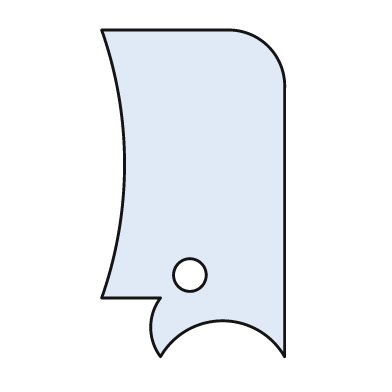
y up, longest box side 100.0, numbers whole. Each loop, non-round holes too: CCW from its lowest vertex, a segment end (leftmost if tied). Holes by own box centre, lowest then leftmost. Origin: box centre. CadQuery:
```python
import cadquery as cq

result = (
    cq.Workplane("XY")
    .moveTo(-10.0, -50.0)
    .threePointArc((9.0, -39.0), (28.0, -50.0))
    .lineTo(28.0, 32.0)
    .threePointArc((23.0, 45.0), (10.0, 50.0))
    .lineTo(-28.0, 50.0)
    .threePointArc((-21.0, 9.0), (-28.0, -32.0))
    .lineTo(-10.0, -32.0)
    .threePointArc((-13.0, -41.0), (-10.0, -50.0))
    .close()
    .moveTo(-1.0, -25.0)
    .circle(5.0)
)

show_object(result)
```